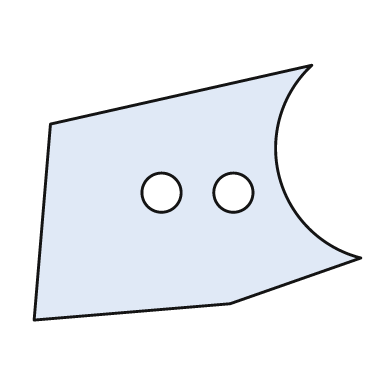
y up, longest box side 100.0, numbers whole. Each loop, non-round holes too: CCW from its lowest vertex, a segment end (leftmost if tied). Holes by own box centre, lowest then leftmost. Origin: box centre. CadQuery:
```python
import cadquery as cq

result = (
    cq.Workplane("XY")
    .moveTo(-50.0, -39.0)
    .lineTo(10.0, -34.0)
    .lineTo(50.0, -20.0)
    .threePointArc((25.0, 5.0), (35.0, 39.0))
    .lineTo(-45.0, 21.0)
    .close()
    .moveTo(-11.0, 0.0)
    .circle(6.0)
    .moveTo(11.0, 0.0)
    .circle(6.0)
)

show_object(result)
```